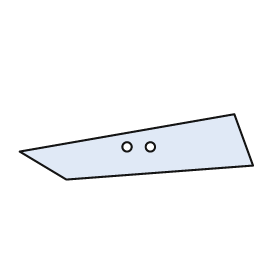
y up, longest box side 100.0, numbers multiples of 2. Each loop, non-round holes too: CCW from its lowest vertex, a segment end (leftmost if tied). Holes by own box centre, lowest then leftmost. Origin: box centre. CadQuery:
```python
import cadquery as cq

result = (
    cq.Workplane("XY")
    .moveTo(-30.0, -14.0)
    .lineTo(50.0, -8.0)
    .lineTo(42.0, 14.0)
    .lineTo(-50.0, -2.0)
    .close()
    .moveTo(-4.0, 0.0)
    .circle(2.0)
    .moveTo(6.0, 0.0)
    .circle(2.0)
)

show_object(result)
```